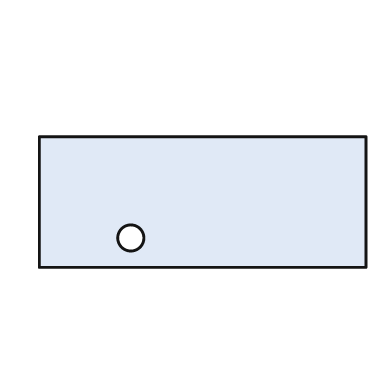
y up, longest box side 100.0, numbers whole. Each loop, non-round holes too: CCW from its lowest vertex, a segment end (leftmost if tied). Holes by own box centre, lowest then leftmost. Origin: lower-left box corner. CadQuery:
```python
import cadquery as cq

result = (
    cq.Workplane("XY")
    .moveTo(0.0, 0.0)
    .lineTo(100.0, 0.0)
    .lineTo(100.0, 40.0)
    .lineTo(0.0, 40.0)
    .close()
    .moveTo(28.0, 9.0)
    .circle(4.0)
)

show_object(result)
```